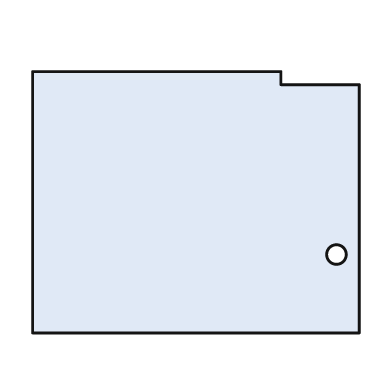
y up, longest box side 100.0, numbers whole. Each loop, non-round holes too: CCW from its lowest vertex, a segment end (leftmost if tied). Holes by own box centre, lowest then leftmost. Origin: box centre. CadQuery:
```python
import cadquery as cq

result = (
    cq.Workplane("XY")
    .moveTo(-50.0, -40.0)
    .lineTo(50.0, -40.0)
    .lineTo(50.0, 36.0)
    .lineTo(26.0, 36.0)
    .lineTo(26.0, 40.0)
    .lineTo(-50.0, 40.0)
    .close()
    .moveTo(43.0, -16.0)
    .circle(3.0)
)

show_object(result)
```